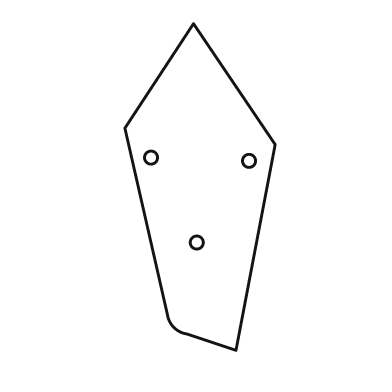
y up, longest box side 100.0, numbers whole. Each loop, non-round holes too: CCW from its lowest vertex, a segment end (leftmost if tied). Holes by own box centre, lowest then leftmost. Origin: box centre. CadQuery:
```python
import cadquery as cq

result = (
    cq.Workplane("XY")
    .moveTo(11.0, -50.0)
    .lineTo(23.0, 13.0)
    .lineTo(-2.0, 50.0)
    .lineTo(-23.0, 18.0)
    .lineTo(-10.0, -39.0)
    .threePointArc((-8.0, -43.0), (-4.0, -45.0))
    .close()
    .moveTo(-1.0, -17.0)
    .circle(2.0)
    .moveTo(15.0, 8.0)
    .circle(2.0)
    .moveTo(-15.0, 9.0)
    .circle(2.0)
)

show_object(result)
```